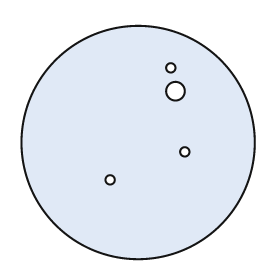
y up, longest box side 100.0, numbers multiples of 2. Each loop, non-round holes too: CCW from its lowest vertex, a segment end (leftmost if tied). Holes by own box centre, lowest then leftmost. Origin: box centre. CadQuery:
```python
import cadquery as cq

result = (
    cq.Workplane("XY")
    .moveTo(0.0, 0.0)
    .circle(50.0)
    .moveTo(-12.0, -16.0)
    .circle(2.0)
    .moveTo(20.0, -4.0)
    .circle(2.0)
    .moveTo(16.0, 22.0)
    .circle(4.0)
    .moveTo(14.0, 32.0)
    .circle(2.0)
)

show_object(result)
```